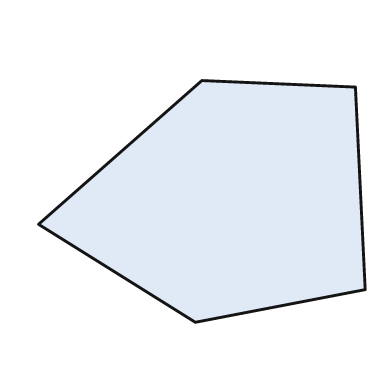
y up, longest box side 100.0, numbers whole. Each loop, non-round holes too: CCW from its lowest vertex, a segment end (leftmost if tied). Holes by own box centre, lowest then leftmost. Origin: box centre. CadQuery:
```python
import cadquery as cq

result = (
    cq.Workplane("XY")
    .moveTo(-2.0, -37.0)
    .lineTo(50.0, -27.0)
    .lineTo(47.0, 35.0)
    .lineTo(0.0, 37.0)
    .lineTo(-50.0, -7.0)
    .close()
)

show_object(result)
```